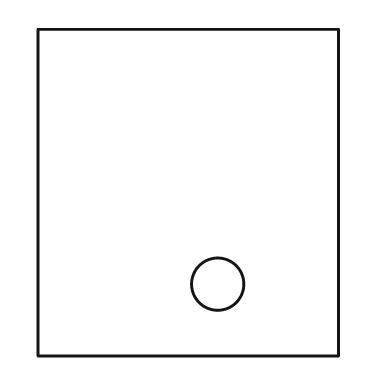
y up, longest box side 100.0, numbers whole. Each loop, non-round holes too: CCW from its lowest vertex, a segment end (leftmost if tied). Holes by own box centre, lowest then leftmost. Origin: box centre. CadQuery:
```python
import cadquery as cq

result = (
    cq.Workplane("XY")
    .moveTo(-46.0, -50.0)
    .lineTo(46.0, -50.0)
    .lineTo(46.0, 50.0)
    .lineTo(-46.0, 50.0)
    .close()
    .moveTo(9.0, -28.0)
    .circle(8.0)
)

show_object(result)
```